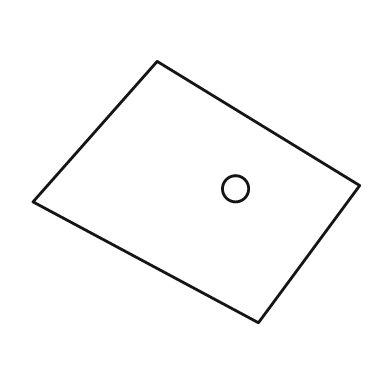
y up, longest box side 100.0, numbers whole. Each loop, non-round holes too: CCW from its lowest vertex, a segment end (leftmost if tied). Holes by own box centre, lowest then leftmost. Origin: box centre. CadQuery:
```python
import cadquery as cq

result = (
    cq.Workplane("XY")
    .moveTo(19.0, -40.0)
    .lineTo(50.0, 2.0)
    .lineTo(-12.0, 40.0)
    .lineTo(-50.0, -3.0)
    .close()
    .moveTo(12.0, 1.0)
    .circle(4.0)
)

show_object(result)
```